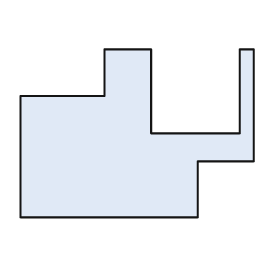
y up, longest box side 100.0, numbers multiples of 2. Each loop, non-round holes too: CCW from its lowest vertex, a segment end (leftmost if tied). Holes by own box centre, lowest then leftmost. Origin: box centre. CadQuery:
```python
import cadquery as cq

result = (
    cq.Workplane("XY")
    .moveTo(-50.0, -36.0)
    .lineTo(26.0, -36.0)
    .lineTo(26.0, -12.0)
    .lineTo(50.0, -12.0)
    .lineTo(50.0, 36.0)
    .lineTo(44.0, 36.0)
    .lineTo(44.0, 0.0)
    .lineTo(6.0, 0.0)
    .lineTo(6.0, 36.0)
    .lineTo(-14.0, 36.0)
    .lineTo(-14.0, 16.0)
    .lineTo(-50.0, 16.0)
    .close()
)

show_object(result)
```